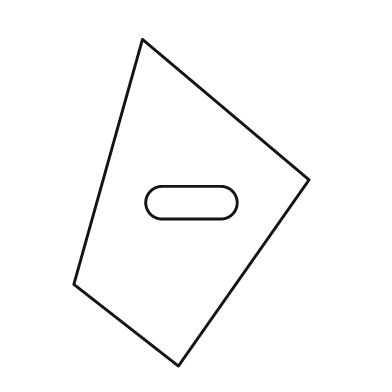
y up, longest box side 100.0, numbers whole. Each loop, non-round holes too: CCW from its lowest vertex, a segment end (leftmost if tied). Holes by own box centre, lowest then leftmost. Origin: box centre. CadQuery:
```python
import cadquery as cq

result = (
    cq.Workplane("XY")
    .moveTo(-4.0, -50.0)
    .lineTo(36.0, 7.0)
    .lineTo(-15.0, 50.0)
    .lineTo(-36.0, -25.0)
    .close()
    .moveTo(-9.0, -5.0)
    .lineTo(9.0, -5.0)
    .threePointArc((14.0, 0.0), (9.0, 5.0))
    .lineTo(-9.0, 5.0)
    .threePointArc((-14.0, 0.0), (-9.0, -5.0))
    .close()
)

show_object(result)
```